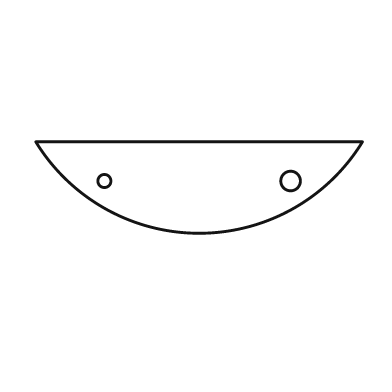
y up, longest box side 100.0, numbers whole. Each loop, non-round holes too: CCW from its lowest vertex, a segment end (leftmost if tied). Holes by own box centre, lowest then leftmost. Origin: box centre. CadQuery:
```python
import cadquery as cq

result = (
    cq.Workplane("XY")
    .moveTo(-50.0, 14.0)
    .threePointArc((0.0, -14.0), (50.0, 14.0))
    .close()
    .moveTo(-29.0, 2.0)
    .circle(2.0)
    .moveTo(28.0, 2.0)
    .circle(3.0)
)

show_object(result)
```